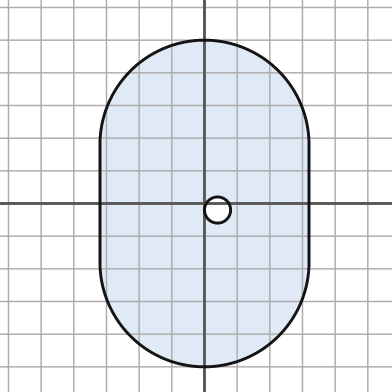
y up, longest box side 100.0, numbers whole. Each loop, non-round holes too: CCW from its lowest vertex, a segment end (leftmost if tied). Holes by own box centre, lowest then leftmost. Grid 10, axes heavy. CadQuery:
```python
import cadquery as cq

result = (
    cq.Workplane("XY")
    .moveTo(-32.0, -18.0)
    .threePointArc((0.0, -50.0), (32.0, -18.0))
    .lineTo(32.0, 18.0)
    .threePointArc((0.0, 50.0), (-32.0, 18.0))
    .close()
    .moveTo(4.0, -2.0)
    .circle(4.0)
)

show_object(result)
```